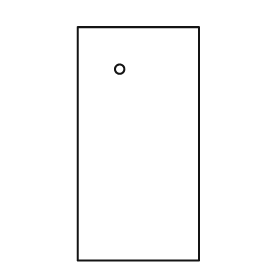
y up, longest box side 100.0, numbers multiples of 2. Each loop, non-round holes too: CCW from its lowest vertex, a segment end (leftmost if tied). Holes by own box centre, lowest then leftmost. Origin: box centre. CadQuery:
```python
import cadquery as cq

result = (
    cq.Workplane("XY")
    .moveTo(-26.0, -50.0)
    .lineTo(26.0, -50.0)
    .lineTo(26.0, 50.0)
    .lineTo(-26.0, 50.0)
    .close()
    .moveTo(-8.0, 32.0)
    .circle(2.0)
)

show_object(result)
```